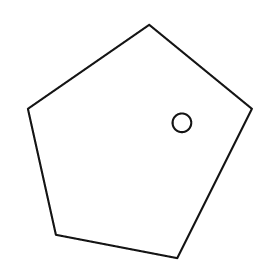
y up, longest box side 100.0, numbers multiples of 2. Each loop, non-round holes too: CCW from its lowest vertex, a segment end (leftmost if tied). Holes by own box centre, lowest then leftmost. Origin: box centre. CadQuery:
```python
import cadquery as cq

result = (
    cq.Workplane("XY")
    .moveTo(16.0, -50.0)
    .lineTo(48.0, 14.0)
    .lineTo(4.0, 50.0)
    .lineTo(-48.0, 14.0)
    .lineTo(-36.0, -40.0)
    .close()
    .moveTo(18.0, 8.0)
    .circle(4.0)
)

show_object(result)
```